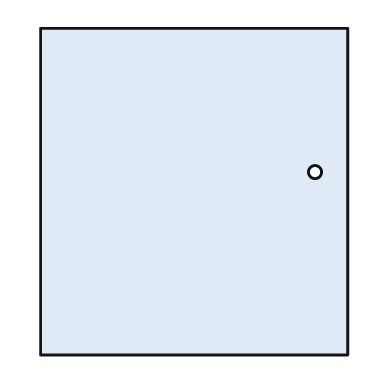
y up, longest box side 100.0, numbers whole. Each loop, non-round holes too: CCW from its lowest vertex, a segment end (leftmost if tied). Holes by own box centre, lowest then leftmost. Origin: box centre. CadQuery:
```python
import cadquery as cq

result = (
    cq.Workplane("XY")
    .moveTo(-47.0, -50.0)
    .lineTo(47.0, -50.0)
    .lineTo(47.0, 50.0)
    .lineTo(-47.0, 50.0)
    .close()
    .moveTo(37.0, 6.0)
    .circle(2.0)
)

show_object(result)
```